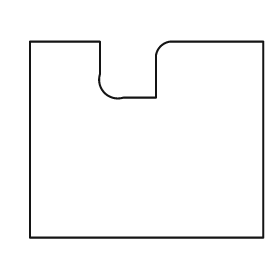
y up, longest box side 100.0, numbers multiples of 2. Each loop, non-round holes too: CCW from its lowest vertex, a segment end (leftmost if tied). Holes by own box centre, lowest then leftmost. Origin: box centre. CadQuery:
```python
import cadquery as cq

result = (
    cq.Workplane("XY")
    .moveTo(-50.0, -42.0)
    .lineTo(50.0, -42.0)
    .lineTo(50.0, 42.0)
    .lineTo(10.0, 42.0)
    .threePointArc((6.0, 40.0), (4.0, 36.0))
    .lineTo(4.0, 18.0)
    .lineTo(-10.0, 18.0)
    .threePointArc((-18.0, 20.0), (-20.0, 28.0))
    .lineTo(-20.0, 42.0)
    .lineTo(-50.0, 42.0)
    .close()
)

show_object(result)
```